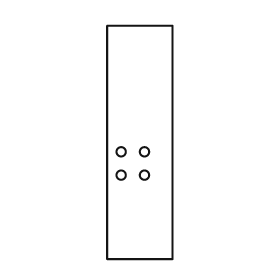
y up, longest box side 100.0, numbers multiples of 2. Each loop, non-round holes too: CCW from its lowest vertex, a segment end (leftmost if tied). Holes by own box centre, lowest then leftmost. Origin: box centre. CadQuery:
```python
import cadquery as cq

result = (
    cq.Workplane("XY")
    .moveTo(-14.0, -50.0)
    .lineTo(14.0, -50.0)
    .lineTo(14.0, 50.0)
    .lineTo(-14.0, 50.0)
    .close()
    .moveTo(-8.0, -14.0)
    .circle(2.0)
    .moveTo(2.0, -14.0)
    .circle(2.0)
    .moveTo(-8.0, -4.0)
    .circle(2.0)
    .moveTo(2.0, -4.0)
    .circle(2.0)
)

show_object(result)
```